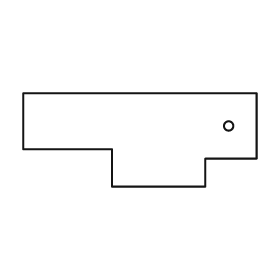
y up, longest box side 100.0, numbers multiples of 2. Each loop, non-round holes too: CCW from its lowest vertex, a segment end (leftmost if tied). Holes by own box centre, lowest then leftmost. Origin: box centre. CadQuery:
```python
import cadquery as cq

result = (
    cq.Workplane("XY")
    .moveTo(-12.0, -20.0)
    .lineTo(28.0, -20.0)
    .lineTo(28.0, -8.0)
    .lineTo(50.0, -8.0)
    .lineTo(50.0, 20.0)
    .lineTo(-50.0, 20.0)
    .lineTo(-50.0, -4.0)
    .lineTo(-12.0, -4.0)
    .close()
    .moveTo(38.0, 6.0)
    .circle(2.0)
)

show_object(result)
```